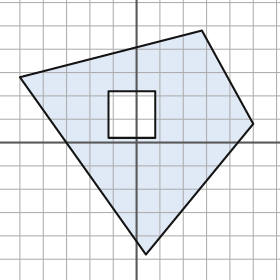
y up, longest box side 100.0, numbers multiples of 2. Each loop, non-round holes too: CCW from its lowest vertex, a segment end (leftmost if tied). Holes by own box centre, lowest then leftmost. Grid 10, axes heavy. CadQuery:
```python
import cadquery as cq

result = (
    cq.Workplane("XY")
    .moveTo(4.0, -48.0)
    .lineTo(50.0, 8.0)
    .lineTo(28.0, 48.0)
    .lineTo(-50.0, 28.0)
    .close()
    .moveTo(-12.0, 2.0)
    .lineTo(8.0, 2.0)
    .lineTo(8.0, 22.0)
    .lineTo(-12.0, 22.0)
    .close()
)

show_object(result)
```